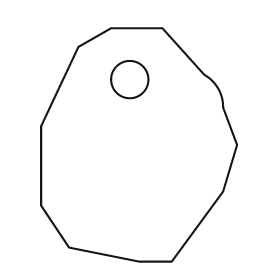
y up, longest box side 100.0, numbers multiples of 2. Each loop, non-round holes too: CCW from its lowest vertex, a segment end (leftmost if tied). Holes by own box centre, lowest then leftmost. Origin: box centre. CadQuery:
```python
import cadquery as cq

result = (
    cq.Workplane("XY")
    .moveTo(0.0, -50.0)
    .lineTo(14.0, -50.0)
    .lineTo(36.0, -20.0)
    .lineTo(42.0, 0.0)
    .lineTo(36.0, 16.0)
    .threePointArc((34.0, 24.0), (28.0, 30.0))
    .lineTo(10.0, 50.0)
    .lineTo(-12.0, 50.0)
    .lineTo(-26.0, 42.0)
    .lineTo(-42.0, 8.0)
    .lineTo(-42.0, -26.0)
    .lineTo(-30.0, -44.0)
    .close()
    .moveTo(-4.0, 28.0)
    .circle(8.0)
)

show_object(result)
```